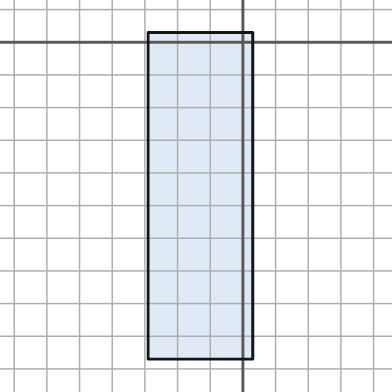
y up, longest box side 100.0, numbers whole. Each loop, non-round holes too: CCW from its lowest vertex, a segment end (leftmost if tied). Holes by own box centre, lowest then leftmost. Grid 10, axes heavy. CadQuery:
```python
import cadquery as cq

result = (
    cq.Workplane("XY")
    .moveTo(-29.0, -97.0)
    .lineTo(3.0, -97.0)
    .lineTo(3.0, 3.0)
    .lineTo(-29.0, 3.0)
    .close()
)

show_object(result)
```